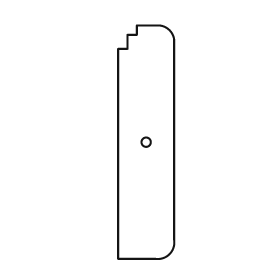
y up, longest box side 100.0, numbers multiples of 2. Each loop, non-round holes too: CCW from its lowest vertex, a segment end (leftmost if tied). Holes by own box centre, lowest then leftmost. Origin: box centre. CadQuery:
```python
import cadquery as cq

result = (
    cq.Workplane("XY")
    .moveTo(-12.0, -50.0)
    .lineTo(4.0, -50.0)
    .threePointArc((10.0, -48.0), (12.0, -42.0))
    .lineTo(12.0, 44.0)
    .threePointArc((10.0, 48.0), (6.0, 50.0))
    .lineTo(-4.0, 50.0)
    .lineTo(-4.0, 46.0)
    .lineTo(-8.0, 46.0)
    .lineTo(-8.0, 40.0)
    .lineTo(-12.0, 40.0)
    .close()
    .moveTo(0.0, 0.0)
    .circle(2.0)
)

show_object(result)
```